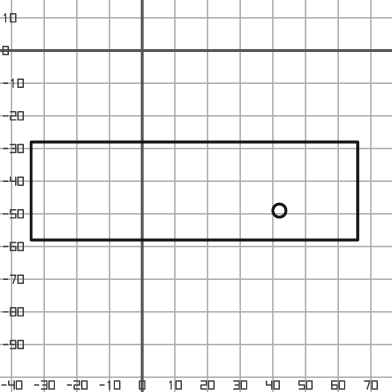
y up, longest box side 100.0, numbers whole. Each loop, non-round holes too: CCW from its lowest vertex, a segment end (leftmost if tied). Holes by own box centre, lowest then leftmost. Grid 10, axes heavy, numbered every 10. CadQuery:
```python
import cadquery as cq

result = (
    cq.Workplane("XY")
    .moveTo(-34.0, -58.0)
    .lineTo(66.0, -58.0)
    .lineTo(66.0, -28.0)
    .lineTo(-34.0, -28.0)
    .close()
    .moveTo(42.0, -49.0)
    .circle(2.0)
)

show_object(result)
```